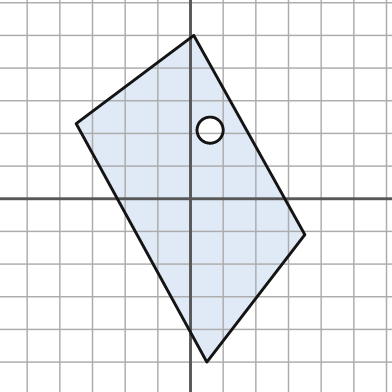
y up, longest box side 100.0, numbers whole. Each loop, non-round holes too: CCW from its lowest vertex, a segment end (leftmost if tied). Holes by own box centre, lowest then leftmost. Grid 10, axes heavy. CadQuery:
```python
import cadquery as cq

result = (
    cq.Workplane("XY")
    .moveTo(5.0, -50.0)
    .lineTo(35.0, -11.0)
    .lineTo(1.0, 50.0)
    .lineTo(-35.0, 23.0)
    .close()
    .moveTo(6.0, 21.0)
    .circle(4.0)
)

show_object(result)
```